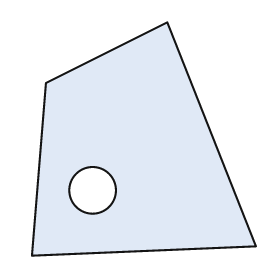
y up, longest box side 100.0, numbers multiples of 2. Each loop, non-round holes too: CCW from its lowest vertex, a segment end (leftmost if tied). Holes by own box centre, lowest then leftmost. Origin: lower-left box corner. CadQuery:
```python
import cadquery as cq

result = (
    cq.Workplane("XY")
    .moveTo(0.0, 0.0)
    .lineTo(96.0, 4.0)
    .lineTo(58.0, 100.0)
    .lineTo(6.0, 74.0)
    .close()
    .moveTo(26.0, 28.0)
    .circle(10.0)
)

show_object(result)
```